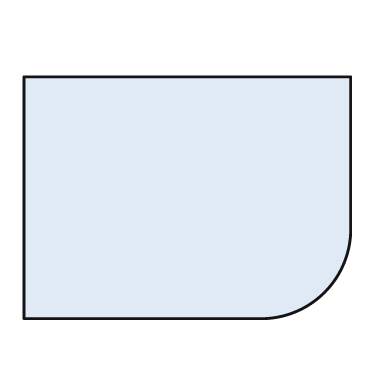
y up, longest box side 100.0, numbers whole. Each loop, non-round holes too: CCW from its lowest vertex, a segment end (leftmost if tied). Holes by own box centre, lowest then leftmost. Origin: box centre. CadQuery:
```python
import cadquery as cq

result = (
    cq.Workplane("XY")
    .moveTo(-50.0, -37.0)
    .lineTo(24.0, -37.0)
    .threePointArc((42.0, -29.0), (50.0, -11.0))
    .lineTo(50.0, 37.0)
    .lineTo(-50.0, 37.0)
    .close()
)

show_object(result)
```